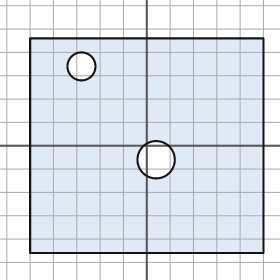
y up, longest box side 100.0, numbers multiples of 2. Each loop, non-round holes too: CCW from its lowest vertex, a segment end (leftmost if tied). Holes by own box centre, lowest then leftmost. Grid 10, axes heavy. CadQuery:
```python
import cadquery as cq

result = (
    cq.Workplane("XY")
    .moveTo(-50.0, -46.0)
    .lineTo(50.0, -46.0)
    .lineTo(50.0, 46.0)
    .lineTo(-50.0, 46.0)
    .close()
    .moveTo(4.0, -6.0)
    .circle(8.0)
    .moveTo(-28.0, 34.0)
    .circle(6.0)
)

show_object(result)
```